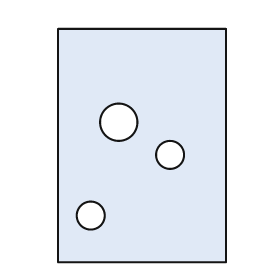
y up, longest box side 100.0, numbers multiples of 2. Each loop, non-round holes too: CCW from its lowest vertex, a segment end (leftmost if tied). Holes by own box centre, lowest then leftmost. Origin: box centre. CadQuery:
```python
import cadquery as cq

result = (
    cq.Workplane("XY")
    .moveTo(-36.0, -50.0)
    .lineTo(36.0, -50.0)
    .lineTo(36.0, 50.0)
    .lineTo(-36.0, 50.0)
    .close()
    .moveTo(-22.0, -30.0)
    .circle(6.0)
    .moveTo(12.0, -4.0)
    .circle(6.0)
    .moveTo(-10.0, 10.0)
    .circle(8.0)
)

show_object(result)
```